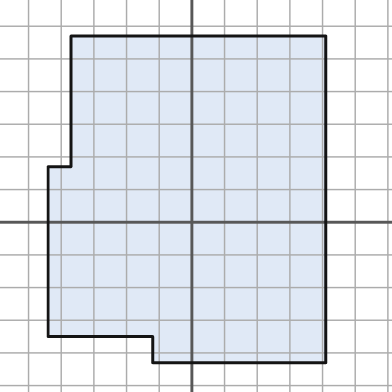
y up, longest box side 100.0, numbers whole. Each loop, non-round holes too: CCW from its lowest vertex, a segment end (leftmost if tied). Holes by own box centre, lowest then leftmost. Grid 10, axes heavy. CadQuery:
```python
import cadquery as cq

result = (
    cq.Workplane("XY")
    .moveTo(-12.0, -43.0)
    .lineTo(41.0, -43.0)
    .lineTo(41.0, 57.0)
    .lineTo(-37.0, 57.0)
    .lineTo(-37.0, 17.0)
    .lineTo(-44.0, 17.0)
    .lineTo(-44.0, -35.0)
    .lineTo(-12.0, -35.0)
    .close()
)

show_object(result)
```